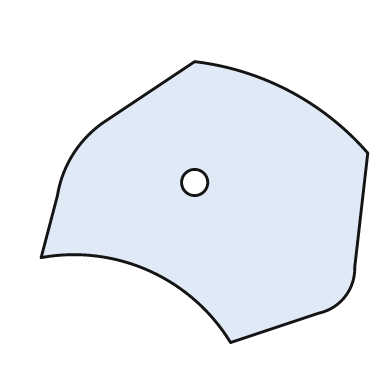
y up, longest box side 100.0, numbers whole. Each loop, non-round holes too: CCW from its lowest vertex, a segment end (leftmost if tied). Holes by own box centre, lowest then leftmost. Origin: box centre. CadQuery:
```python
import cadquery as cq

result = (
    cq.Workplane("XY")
    .moveTo(8.0, -43.0)
    .lineTo(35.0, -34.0)
    .threePointArc((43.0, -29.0), (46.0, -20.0))
    .lineTo(50.0, 15.0)
    .threePointArc((26.0, 34.0), (-3.0, 43.0))
    .lineTo(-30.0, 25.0)
    .threePointArc((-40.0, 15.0), (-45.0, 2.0))
    .lineTo(-50.0, -17.0)
    .threePointArc((-17.0, -21.0), (8.0, -43.0))
    .close()
    .moveTo(-3.0, 6.0)
    .circle(4.0)
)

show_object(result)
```